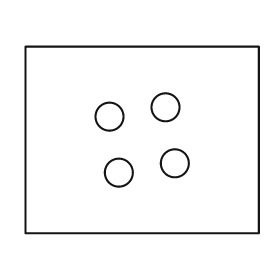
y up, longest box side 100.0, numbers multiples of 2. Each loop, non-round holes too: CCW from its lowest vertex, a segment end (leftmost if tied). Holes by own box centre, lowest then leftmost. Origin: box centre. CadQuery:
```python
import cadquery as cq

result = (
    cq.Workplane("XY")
    .moveTo(-50.0, -40.0)
    .lineTo(50.0, -40.0)
    .lineTo(50.0, 40.0)
    .lineTo(-50.0, 40.0)
    .close()
    .moveTo(-10.0, -14.0)
    .circle(6.0)
    .moveTo(14.0, -10.0)
    .circle(6.0)
    .moveTo(-14.0, 10.0)
    .circle(6.0)
    .moveTo(10.0, 14.0)
    .circle(6.0)
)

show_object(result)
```